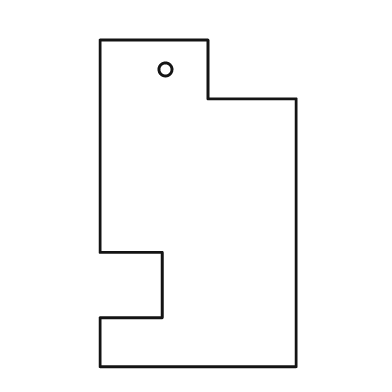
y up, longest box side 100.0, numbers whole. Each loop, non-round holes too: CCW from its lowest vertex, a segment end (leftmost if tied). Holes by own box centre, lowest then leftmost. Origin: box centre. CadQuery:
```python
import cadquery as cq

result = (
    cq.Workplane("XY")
    .moveTo(-30.0, -50.0)
    .lineTo(30.0, -50.0)
    .lineTo(30.0, 32.0)
    .lineTo(3.0, 32.0)
    .lineTo(3.0, 50.0)
    .lineTo(-30.0, 50.0)
    .lineTo(-30.0, -15.0)
    .lineTo(-11.0, -15.0)
    .lineTo(-11.0, -35.0)
    .lineTo(-30.0, -35.0)
    .close()
    .moveTo(-10.0, 41.0)
    .circle(2.0)
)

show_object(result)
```